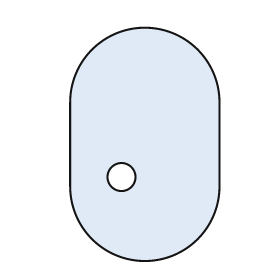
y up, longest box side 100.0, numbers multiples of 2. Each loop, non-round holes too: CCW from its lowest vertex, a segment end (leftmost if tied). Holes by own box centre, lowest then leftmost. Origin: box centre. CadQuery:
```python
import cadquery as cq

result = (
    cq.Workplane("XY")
    .moveTo(-32.0, -18.0)
    .threePointArc((0.0, -50.0), (32.0, -18.0))
    .lineTo(32.0, 18.0)
    .threePointArc((0.0, 50.0), (-32.0, 18.0))
    .close()
    .moveTo(-10.0, -14.0)
    .circle(6.0)
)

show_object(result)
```